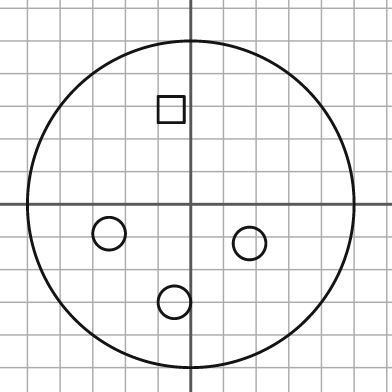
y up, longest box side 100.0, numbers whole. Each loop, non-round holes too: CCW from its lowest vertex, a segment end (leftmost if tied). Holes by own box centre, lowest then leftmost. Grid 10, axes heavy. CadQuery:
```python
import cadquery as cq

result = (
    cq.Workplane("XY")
    .moveTo(0.0, 0.0)
    .circle(50.0)
    .moveTo(-5.0, -30.0)
    .circle(5.0)
    .moveTo(18.0, -12.0)
    .circle(5.0)
    .moveTo(-25.0, -9.0)
    .circle(5.0)
    .moveTo(-10.0, 25.0)
    .lineTo(-2.0, 25.0)
    .lineTo(-2.0, 33.0)
    .lineTo(-10.0, 33.0)
    .close()
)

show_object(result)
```